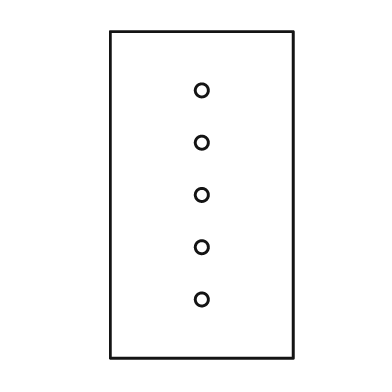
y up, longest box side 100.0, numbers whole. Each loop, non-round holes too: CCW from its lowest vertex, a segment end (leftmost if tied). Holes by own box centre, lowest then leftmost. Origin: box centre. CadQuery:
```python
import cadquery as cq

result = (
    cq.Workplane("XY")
    .moveTo(-28.0, -50.0)
    .lineTo(28.0, -50.0)
    .lineTo(28.0, 50.0)
    .lineTo(-28.0, 50.0)
    .close()
    .moveTo(0.0, -32.0)
    .circle(2.0)
    .moveTo(0.0, -16.0)
    .circle(2.0)
    .moveTo(0.0, 0.0)
    .circle(2.0)
    .moveTo(0.0, 16.0)
    .circle(2.0)
    .moveTo(0.0, 32.0)
    .circle(2.0)
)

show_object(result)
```